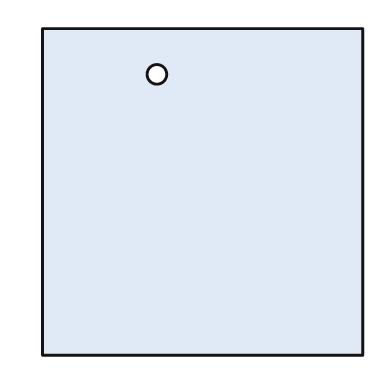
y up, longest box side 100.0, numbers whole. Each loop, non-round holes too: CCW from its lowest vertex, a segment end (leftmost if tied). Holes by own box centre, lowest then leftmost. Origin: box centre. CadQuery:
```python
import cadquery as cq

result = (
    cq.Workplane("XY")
    .moveTo(-49.0, -50.0)
    .lineTo(49.0, -50.0)
    .lineTo(49.0, 50.0)
    .lineTo(-49.0, 50.0)
    .close()
    .moveTo(-14.0, 36.0)
    .circle(3.0)
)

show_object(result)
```